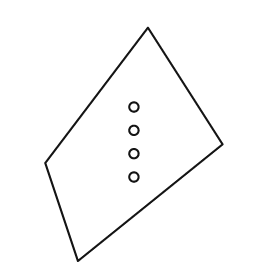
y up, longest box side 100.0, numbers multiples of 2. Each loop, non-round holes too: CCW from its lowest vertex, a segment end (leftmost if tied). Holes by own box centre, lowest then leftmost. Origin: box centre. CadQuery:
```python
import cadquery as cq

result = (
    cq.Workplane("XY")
    .moveTo(-24.0, -50.0)
    .lineTo(38.0, 0.0)
    .lineTo(6.0, 50.0)
    .lineTo(-38.0, -8.0)
    .close()
    .moveTo(0.0, -14.0)
    .circle(2.0)
    .moveTo(0.0, -4.0)
    .circle(2.0)
    .moveTo(0.0, 6.0)
    .circle(2.0)
    .moveTo(0.0, 16.0)
    .circle(2.0)
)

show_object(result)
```